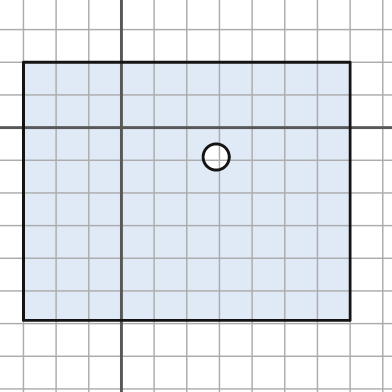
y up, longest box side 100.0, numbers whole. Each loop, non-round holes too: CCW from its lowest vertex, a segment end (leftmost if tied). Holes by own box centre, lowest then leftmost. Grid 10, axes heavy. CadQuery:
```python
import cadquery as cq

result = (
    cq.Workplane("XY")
    .moveTo(-30.0, -59.0)
    .lineTo(70.0, -59.0)
    .lineTo(70.0, 20.0)
    .lineTo(-30.0, 20.0)
    .close()
    .moveTo(29.0, -9.0)
    .circle(4.0)
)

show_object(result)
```